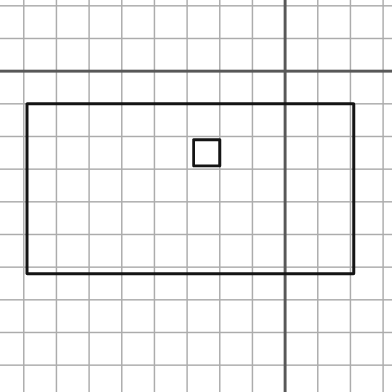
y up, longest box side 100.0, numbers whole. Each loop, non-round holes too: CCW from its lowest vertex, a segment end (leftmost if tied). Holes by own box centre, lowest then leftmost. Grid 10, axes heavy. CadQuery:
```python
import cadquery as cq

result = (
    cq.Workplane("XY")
    .moveTo(-79.0, -62.0)
    .lineTo(21.0, -62.0)
    .lineTo(21.0, -10.0)
    .lineTo(-79.0, -10.0)
    .close()
    .moveTo(-28.0, -29.0)
    .lineTo(-20.0, -29.0)
    .lineTo(-20.0, -21.0)
    .lineTo(-28.0, -21.0)
    .close()
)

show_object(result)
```